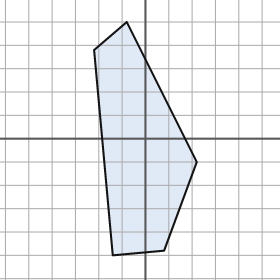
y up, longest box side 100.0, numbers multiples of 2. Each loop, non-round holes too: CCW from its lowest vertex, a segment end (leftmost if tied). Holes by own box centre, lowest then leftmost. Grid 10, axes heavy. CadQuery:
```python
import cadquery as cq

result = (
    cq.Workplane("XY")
    .moveTo(-14.0, -50.0)
    .lineTo(8.0, -48.0)
    .lineTo(22.0, -10.0)
    .lineTo(-8.0, 50.0)
    .lineTo(-22.0, 38.0)
    .close()
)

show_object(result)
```